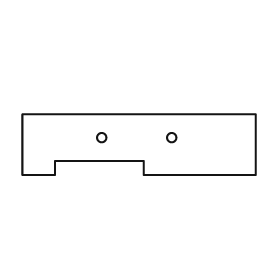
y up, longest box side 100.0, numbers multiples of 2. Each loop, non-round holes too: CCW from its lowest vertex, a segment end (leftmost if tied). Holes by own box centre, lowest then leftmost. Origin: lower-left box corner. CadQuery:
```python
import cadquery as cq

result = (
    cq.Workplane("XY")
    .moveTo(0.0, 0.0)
    .lineTo(14.0, 0.0)
    .lineTo(14.0, 6.0)
    .lineTo(52.0, 6.0)
    .lineTo(52.0, 0.0)
    .lineTo(100.0, 0.0)
    .lineTo(100.0, 26.0)
    .lineTo(0.0, 26.0)
    .close()
    .moveTo(34.0, 16.0)
    .circle(2.0)
    .moveTo(64.0, 16.0)
    .circle(2.0)
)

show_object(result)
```